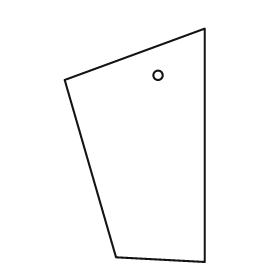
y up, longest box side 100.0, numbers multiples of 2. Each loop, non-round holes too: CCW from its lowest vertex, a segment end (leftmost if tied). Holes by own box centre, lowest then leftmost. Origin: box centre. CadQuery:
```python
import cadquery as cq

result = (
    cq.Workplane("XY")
    .moveTo(30.0, -50.0)
    .lineTo(30.0, 50.0)
    .lineTo(-30.0, 28.0)
    .lineTo(-8.0, -48.0)
    .close()
    .moveTo(10.0, 30.0)
    .circle(2.0)
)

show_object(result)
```